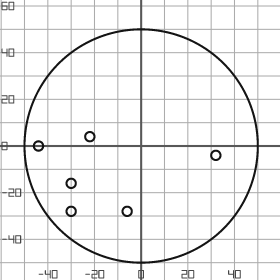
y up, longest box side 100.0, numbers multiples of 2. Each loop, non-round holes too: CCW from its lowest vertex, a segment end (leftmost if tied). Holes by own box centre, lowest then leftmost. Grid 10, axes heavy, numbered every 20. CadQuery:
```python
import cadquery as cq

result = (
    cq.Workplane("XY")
    .moveTo(0.0, 0.0)
    .circle(50.0)
    .moveTo(-30.0, -28.0)
    .circle(2.0)
    .moveTo(-6.0, -28.0)
    .circle(2.0)
    .moveTo(-30.0, -16.0)
    .circle(2.0)
    .moveTo(32.0, -4.0)
    .circle(2.0)
    .moveTo(-44.0, 0.0)
    .circle(2.0)
    .moveTo(-22.0, 4.0)
    .circle(2.0)
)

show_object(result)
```